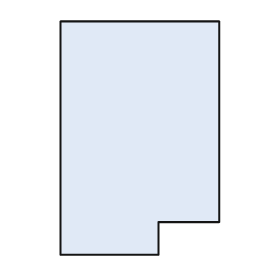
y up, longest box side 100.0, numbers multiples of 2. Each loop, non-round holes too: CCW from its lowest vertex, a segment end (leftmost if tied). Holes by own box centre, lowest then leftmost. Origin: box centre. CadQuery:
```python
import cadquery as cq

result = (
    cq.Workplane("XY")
    .moveTo(-34.0, -50.0)
    .lineTo(8.0, -50.0)
    .lineTo(8.0, -36.0)
    .lineTo(34.0, -36.0)
    .lineTo(34.0, 50.0)
    .lineTo(-34.0, 50.0)
    .close()
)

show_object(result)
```